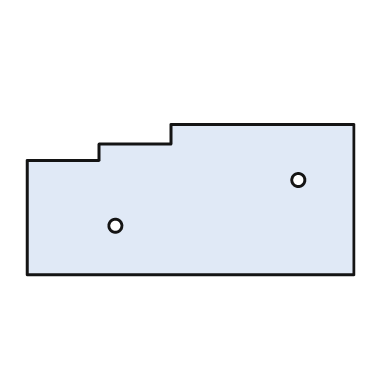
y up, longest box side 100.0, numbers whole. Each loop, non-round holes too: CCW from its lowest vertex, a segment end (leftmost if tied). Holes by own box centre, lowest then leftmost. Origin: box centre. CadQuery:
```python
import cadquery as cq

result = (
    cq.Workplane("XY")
    .moveTo(-50.0, -23.0)
    .lineTo(50.0, -23.0)
    .lineTo(50.0, 23.0)
    .lineTo(-6.0, 23.0)
    .lineTo(-6.0, 17.0)
    .lineTo(-28.0, 17.0)
    .lineTo(-28.0, 12.0)
    .lineTo(-50.0, 12.0)
    .close()
    .moveTo(-23.0, -8.0)
    .circle(2.0)
    .moveTo(33.0, 6.0)
    .circle(2.0)
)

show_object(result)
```